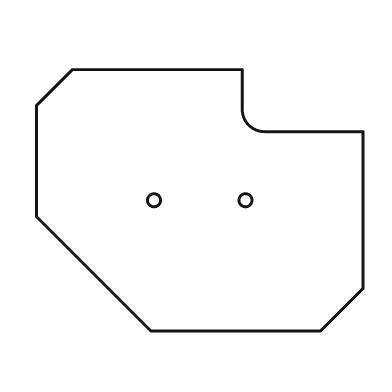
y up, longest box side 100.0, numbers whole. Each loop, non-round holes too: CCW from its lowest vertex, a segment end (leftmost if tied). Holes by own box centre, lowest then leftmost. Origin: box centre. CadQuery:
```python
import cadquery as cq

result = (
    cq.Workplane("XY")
    .moveTo(-15.0, -40.0)
    .lineTo(37.0, -40.0)
    .lineTo(50.0, -27.0)
    .lineTo(50.0, 21.0)
    .lineTo(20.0, 21.0)
    .threePointArc((15.0, 23.0), (13.0, 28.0))
    .lineTo(13.0, 40.0)
    .lineTo(-39.0, 40.0)
    .lineTo(-50.0, 29.0)
    .lineTo(-50.0, -5.0)
    .close()
    .moveTo(-14.0, 0.0)
    .circle(2.0)
    .moveTo(14.0, 0.0)
    .circle(2.0)
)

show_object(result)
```